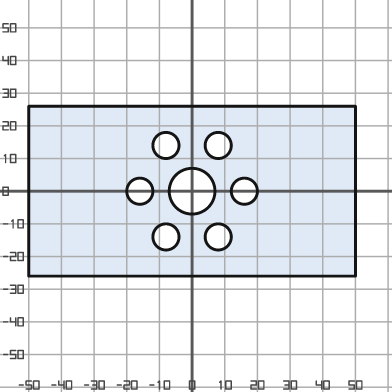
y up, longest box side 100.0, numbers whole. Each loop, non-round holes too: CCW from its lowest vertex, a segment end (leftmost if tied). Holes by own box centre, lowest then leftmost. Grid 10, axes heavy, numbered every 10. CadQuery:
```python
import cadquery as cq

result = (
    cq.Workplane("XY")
    .moveTo(-50.0, -26.0)
    .lineTo(50.0, -26.0)
    .lineTo(50.0, 26.0)
    .lineTo(-50.0, 26.0)
    .close()
    .moveTo(-8.0, -14.0)
    .circle(4.0)
    .moveTo(8.0, -14.0)
    .circle(4.0)
    .moveTo(-16.0, 0.0)
    .circle(4.0)
    .moveTo(0.0, 0.0)
    .circle(7.0)
    .moveTo(16.0, 0.0)
    .circle(4.0)
    .moveTo(-8.0, 14.0)
    .circle(4.0)
    .moveTo(8.0, 14.0)
    .circle(4.0)
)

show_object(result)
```